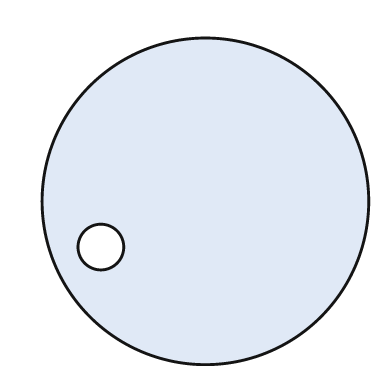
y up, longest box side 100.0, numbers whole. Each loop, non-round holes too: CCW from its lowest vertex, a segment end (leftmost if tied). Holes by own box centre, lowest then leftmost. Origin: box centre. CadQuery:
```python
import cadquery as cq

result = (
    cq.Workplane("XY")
    .moveTo(0.0, 0.0)
    .circle(50.0)
    .moveTo(-32.0, -14.0)
    .circle(7.0)
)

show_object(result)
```